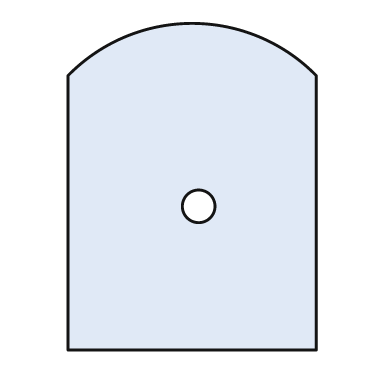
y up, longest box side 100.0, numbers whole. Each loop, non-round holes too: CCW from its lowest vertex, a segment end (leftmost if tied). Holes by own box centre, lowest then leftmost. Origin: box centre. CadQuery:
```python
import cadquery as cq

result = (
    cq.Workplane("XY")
    .moveTo(-38.0, -50.0)
    .lineTo(38.0, -50.0)
    .lineTo(38.0, 34.0)
    .threePointArc((0.0, 50.0), (-38.0, 34.0))
    .close()
    .moveTo(2.0, -6.0)
    .circle(5.0)
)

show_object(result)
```